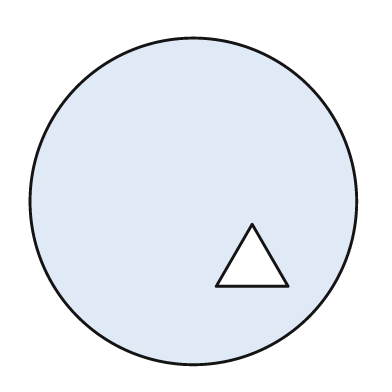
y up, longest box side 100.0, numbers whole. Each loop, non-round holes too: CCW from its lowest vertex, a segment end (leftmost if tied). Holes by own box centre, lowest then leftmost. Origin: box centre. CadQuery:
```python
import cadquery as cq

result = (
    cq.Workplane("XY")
    .moveTo(0.0, 0.0)
    .circle(50.0)
    .moveTo(7.0, -26.0)
    .lineTo(29.0, -26.0)
    .lineTo(18.0, -7.0)
    .close()
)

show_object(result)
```